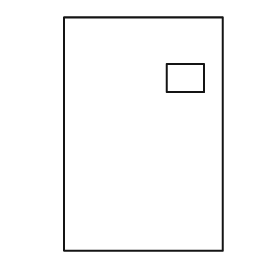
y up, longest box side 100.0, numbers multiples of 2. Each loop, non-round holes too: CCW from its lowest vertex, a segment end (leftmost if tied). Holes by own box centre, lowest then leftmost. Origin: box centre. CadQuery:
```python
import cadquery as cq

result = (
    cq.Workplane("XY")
    .moveTo(-34.0, -50.0)
    .lineTo(34.0, -50.0)
    .lineTo(34.0, 50.0)
    .lineTo(-34.0, 50.0)
    .close()
    .moveTo(10.0, 18.0)
    .lineTo(26.0, 18.0)
    .lineTo(26.0, 30.0)
    .lineTo(10.0, 30.0)
    .close()
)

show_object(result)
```